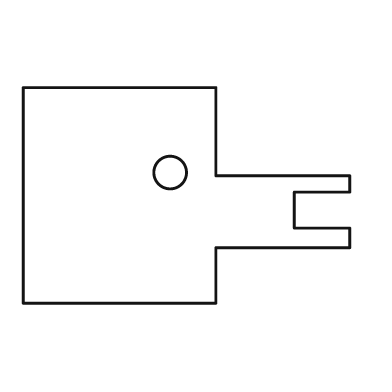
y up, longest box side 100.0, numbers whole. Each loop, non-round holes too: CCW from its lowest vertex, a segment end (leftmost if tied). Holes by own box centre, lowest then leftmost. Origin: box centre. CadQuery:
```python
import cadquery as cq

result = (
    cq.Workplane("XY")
    .moveTo(-50.0, -33.0)
    .lineTo(9.0, -33.0)
    .lineTo(9.0, -16.0)
    .lineTo(50.0, -16.0)
    .lineTo(50.0, -10.0)
    .lineTo(33.0, -10.0)
    .lineTo(33.0, 1.0)
    .lineTo(50.0, 1.0)
    .lineTo(50.0, 6.0)
    .lineTo(9.0, 6.0)
    .lineTo(9.0, 33.0)
    .lineTo(-50.0, 33.0)
    .close()
    .moveTo(-5.0, 7.0)
    .circle(5.0)
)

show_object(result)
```